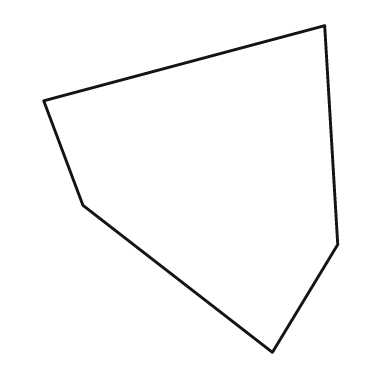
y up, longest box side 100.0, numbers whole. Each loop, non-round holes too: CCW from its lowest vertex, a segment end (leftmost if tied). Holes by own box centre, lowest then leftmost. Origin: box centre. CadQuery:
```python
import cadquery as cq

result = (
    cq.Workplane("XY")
    .moveTo(25.0, -50.0)
    .lineTo(45.0, -17.0)
    .lineTo(41.0, 50.0)
    .lineTo(-45.0, 27.0)
    .lineTo(-33.0, -5.0)
    .close()
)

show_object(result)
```